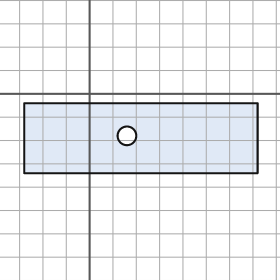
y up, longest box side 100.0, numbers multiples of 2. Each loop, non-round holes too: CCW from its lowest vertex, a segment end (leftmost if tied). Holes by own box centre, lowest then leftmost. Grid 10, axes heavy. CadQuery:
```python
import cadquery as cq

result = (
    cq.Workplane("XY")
    .moveTo(-28.0, -34.0)
    .lineTo(72.0, -34.0)
    .lineTo(72.0, -4.0)
    .lineTo(-28.0, -4.0)
    .close()
    .moveTo(16.0, -18.0)
    .circle(4.0)
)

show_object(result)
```